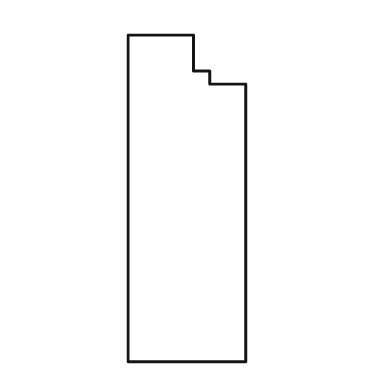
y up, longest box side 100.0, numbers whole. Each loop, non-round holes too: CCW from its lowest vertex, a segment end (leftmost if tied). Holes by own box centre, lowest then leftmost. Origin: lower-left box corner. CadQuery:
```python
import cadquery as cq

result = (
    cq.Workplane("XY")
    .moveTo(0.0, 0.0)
    .lineTo(36.0, 0.0)
    .lineTo(36.0, 85.0)
    .lineTo(25.0, 85.0)
    .lineTo(25.0, 89.0)
    .lineTo(20.0, 89.0)
    .lineTo(20.0, 100.0)
    .lineTo(0.0, 100.0)
    .close()
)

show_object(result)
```